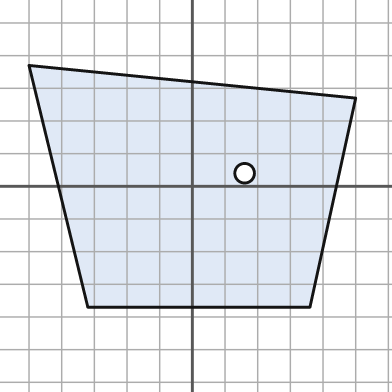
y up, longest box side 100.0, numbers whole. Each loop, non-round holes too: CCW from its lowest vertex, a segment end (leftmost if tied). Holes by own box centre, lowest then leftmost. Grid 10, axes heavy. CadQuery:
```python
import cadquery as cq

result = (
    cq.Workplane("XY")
    .moveTo(-32.0, -37.0)
    .lineTo(36.0, -37.0)
    .lineTo(50.0, 27.0)
    .lineTo(-50.0, 37.0)
    .close()
    .moveTo(16.0, 4.0)
    .circle(3.0)
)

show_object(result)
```